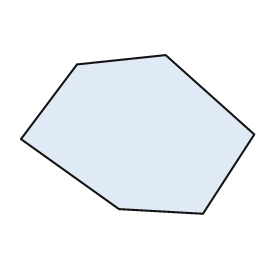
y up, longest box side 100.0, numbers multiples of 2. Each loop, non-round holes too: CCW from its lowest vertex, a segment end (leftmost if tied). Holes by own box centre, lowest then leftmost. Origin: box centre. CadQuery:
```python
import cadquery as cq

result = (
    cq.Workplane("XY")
    .moveTo(28.0, -34.0)
    .lineTo(50.0, 0.0)
    .lineTo(12.0, 34.0)
    .lineTo(-26.0, 30.0)
    .lineTo(-50.0, -2.0)
    .lineTo(-8.0, -32.0)
    .close()
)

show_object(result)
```